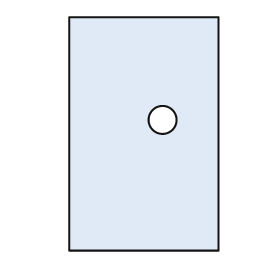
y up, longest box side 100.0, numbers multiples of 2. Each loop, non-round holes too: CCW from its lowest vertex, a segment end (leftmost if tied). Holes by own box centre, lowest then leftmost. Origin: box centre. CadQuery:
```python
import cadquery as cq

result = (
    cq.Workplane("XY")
    .moveTo(-32.0, -50.0)
    .lineTo(32.0, -50.0)
    .lineTo(32.0, 50.0)
    .lineTo(-32.0, 50.0)
    .close()
    .moveTo(8.0, 6.0)
    .circle(6.0)
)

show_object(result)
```